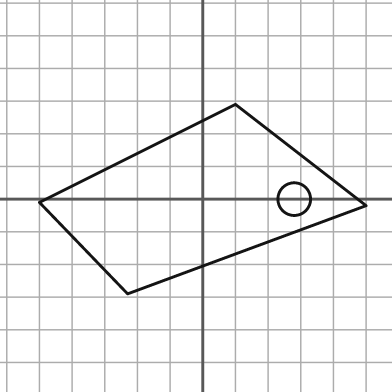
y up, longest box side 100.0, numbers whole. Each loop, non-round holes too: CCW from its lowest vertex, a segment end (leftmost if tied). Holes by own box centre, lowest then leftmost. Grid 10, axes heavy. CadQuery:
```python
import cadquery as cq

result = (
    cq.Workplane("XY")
    .moveTo(-23.0, -29.0)
    .lineTo(50.0, -2.0)
    .lineTo(10.0, 29.0)
    .lineTo(-50.0, -1.0)
    .close()
    .moveTo(28.0, 0.0)
    .circle(5.0)
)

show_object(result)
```